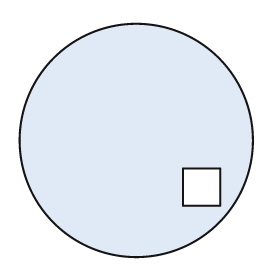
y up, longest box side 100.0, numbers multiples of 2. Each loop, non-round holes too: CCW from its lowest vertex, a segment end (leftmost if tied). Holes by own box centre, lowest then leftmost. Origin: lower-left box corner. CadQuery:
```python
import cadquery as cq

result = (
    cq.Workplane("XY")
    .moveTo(50.0, 50.0)
    .circle(50.0)
    .moveTo(70.0, 22.0)
    .lineTo(86.0, 22.0)
    .lineTo(86.0, 38.0)
    .lineTo(70.0, 38.0)
    .close()
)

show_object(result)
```